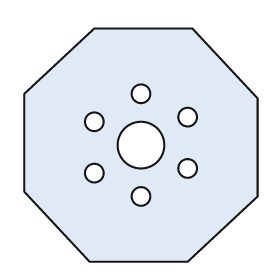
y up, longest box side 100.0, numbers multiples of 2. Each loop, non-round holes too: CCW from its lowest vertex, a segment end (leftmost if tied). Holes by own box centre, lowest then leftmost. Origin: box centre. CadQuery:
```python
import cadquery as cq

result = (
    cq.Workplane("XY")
    .moveTo(-22.0, -50.0)
    .lineTo(20.0, -50.0)
    .lineTo(50.0, -22.0)
    .lineTo(50.0, 20.0)
    .lineTo(22.0, 50.0)
    .lineTo(-20.0, 50.0)
    .lineTo(-50.0, 22.0)
    .lineTo(-50.0, -20.0)
    .close()
    .moveTo(0.0, -22.0)
    .circle(4.0)
    .moveTo(-20.0, -12.0)
    .circle(4.0)
    .moveTo(20.0, -10.0)
    .circle(4.0)
    .moveTo(0.0, 0.0)
    .circle(10.0)
    .moveTo(-20.0, 10.0)
    .circle(4.0)
    .moveTo(20.0, 12.0)
    .circle(4.0)
    .moveTo(0.0, 22.0)
    .circle(4.0)
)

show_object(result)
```